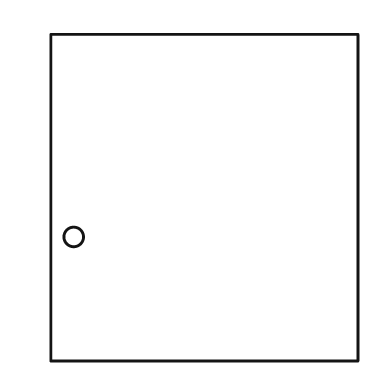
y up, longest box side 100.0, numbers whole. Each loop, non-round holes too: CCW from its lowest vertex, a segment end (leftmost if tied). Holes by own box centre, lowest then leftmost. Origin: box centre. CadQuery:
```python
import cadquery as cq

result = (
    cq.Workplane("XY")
    .moveTo(-47.0, -50.0)
    .lineTo(47.0, -50.0)
    .lineTo(47.0, 50.0)
    .lineTo(-47.0, 50.0)
    .close()
    .moveTo(-40.0, -12.0)
    .circle(3.0)
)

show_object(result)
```